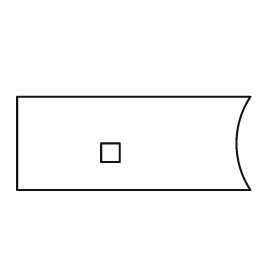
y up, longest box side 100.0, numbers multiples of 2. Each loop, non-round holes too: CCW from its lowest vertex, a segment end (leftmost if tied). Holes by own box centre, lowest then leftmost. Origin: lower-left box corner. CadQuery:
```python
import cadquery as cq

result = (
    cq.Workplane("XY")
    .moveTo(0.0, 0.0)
    .lineTo(100.0, 0.0)
    .threePointArc((94.0, 20.0), (100.0, 40.0))
    .lineTo(0.0, 40.0)
    .close()
    .moveTo(36.0, 12.0)
    .lineTo(44.0, 12.0)
    .lineTo(44.0, 20.0)
    .lineTo(36.0, 20.0)
    .close()
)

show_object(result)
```